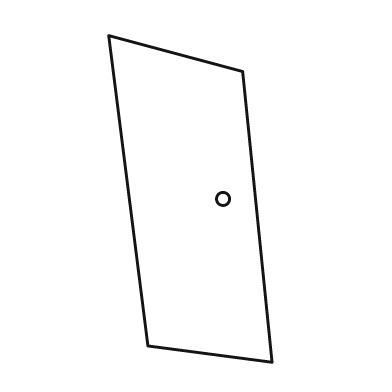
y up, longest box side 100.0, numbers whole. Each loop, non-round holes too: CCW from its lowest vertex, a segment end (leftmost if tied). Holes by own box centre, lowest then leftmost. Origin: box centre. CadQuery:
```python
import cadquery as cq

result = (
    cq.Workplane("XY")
    .moveTo(25.0, -50.0)
    .lineTo(16.0, 39.0)
    .lineTo(-25.0, 50.0)
    .lineTo(-13.0, -45.0)
    .close()
    .moveTo(10.0, 0.0)
    .circle(2.0)
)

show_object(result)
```